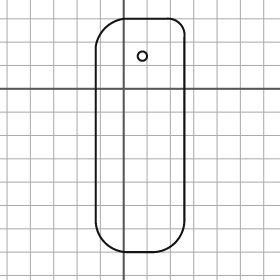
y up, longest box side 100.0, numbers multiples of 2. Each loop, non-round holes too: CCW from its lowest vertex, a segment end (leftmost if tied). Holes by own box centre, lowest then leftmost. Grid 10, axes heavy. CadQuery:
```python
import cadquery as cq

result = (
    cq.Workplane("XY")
    .moveTo(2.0, -70.0)
    .lineTo(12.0, -70.0)
    .threePointArc((22.0, -66.0), (26.0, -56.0))
    .lineTo(26.0, 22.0)
    .threePointArc((24.0, 28.0), (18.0, 30.0))
    .lineTo(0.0, 30.0)
    .threePointArc((-8.0, 26.0), (-12.0, 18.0))
    .lineTo(-12.0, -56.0)
    .threePointArc((-8.0, -66.0), (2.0, -70.0))
    .close()
    .moveTo(8.0, 14.0)
    .circle(2.0)
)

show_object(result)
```